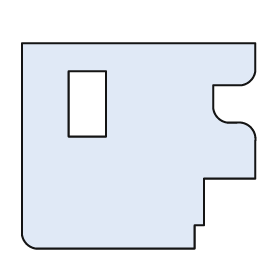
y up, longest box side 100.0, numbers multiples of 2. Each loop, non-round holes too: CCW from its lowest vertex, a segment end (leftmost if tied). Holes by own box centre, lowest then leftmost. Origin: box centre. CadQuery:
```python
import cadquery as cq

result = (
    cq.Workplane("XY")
    .moveTo(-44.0, -44.0)
    .lineTo(24.0, -44.0)
    .lineTo(24.0, -34.0)
    .lineTo(28.0, -34.0)
    .lineTo(28.0, -14.0)
    .lineTo(50.0, -14.0)
    .lineTo(50.0, 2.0)
    .threePointArc((48.0, 8.0), (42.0, 10.0))
    .lineTo(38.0, 10.0)
    .threePointArc((34.0, 12.0), (32.0, 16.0))
    .lineTo(32.0, 26.0)
    .lineTo(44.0, 26.0)
    .threePointArc((48.0, 28.0), (50.0, 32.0))
    .lineTo(50.0, 44.0)
    .lineTo(-50.0, 44.0)
    .lineTo(-50.0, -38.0)
    .threePointArc((-48.0, -42.0), (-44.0, -44.0))
    .close()
    .moveTo(-30.0, 4.0)
    .lineTo(-14.0, 4.0)
    .lineTo(-14.0, 32.0)
    .lineTo(-30.0, 32.0)
    .close()
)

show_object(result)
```